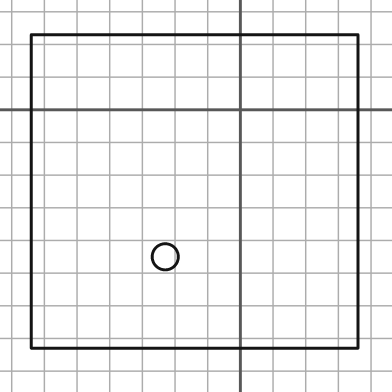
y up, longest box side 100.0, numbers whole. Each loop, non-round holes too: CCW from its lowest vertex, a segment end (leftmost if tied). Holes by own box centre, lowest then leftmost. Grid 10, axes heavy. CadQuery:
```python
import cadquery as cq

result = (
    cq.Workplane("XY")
    .moveTo(-64.0, -73.0)
    .lineTo(36.0, -73.0)
    .lineTo(36.0, 23.0)
    .lineTo(-64.0, 23.0)
    .close()
    .moveTo(-23.0, -45.0)
    .circle(4.0)
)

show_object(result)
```